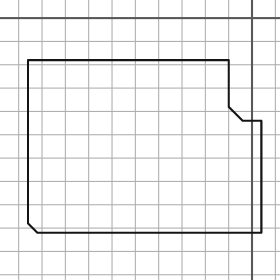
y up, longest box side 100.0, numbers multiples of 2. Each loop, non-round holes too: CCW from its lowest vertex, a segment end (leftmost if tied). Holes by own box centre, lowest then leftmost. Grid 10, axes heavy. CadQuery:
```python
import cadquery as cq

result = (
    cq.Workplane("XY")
    .moveTo(-92.0, -92.0)
    .lineTo(4.0, -92.0)
    .lineTo(4.0, -44.0)
    .lineTo(-4.0, -44.0)
    .lineTo(-10.0, -38.0)
    .lineTo(-10.0, -18.0)
    .lineTo(-96.0, -18.0)
    .lineTo(-96.0, -88.0)
    .close()
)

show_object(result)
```